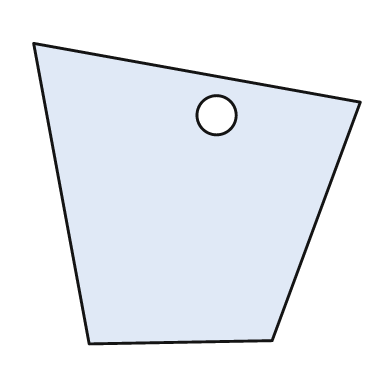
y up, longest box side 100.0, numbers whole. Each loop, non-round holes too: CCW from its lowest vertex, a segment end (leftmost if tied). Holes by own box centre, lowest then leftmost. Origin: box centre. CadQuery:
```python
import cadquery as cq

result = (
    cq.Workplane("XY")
    .moveTo(-33.0, -46.0)
    .lineTo(23.0, -45.0)
    .lineTo(50.0, 28.0)
    .lineTo(-50.0, 46.0)
    .close()
    .moveTo(6.0, 24.0)
    .circle(6.0)
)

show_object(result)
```